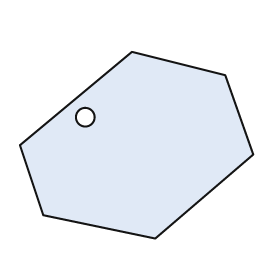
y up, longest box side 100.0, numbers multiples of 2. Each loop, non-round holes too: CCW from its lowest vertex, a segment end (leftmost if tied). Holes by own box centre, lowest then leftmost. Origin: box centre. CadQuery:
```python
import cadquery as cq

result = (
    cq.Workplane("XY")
    .moveTo(8.0, -40.0)
    .lineTo(50.0, -4.0)
    .lineTo(38.0, 30.0)
    .lineTo(-2.0, 40.0)
    .lineTo(-50.0, 0.0)
    .lineTo(-40.0, -30.0)
    .close()
    .moveTo(-22.0, 12.0)
    .circle(4.0)
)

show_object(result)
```